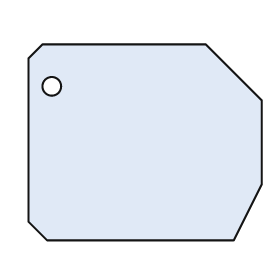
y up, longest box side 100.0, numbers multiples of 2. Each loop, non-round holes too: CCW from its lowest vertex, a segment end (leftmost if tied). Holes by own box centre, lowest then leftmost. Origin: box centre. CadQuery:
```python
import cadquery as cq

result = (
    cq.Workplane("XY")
    .moveTo(-42.0, -42.0)
    .lineTo(38.0, -42.0)
    .lineTo(50.0, -18.0)
    .lineTo(50.0, 18.0)
    .lineTo(26.0, 42.0)
    .lineTo(-44.0, 42.0)
    .lineTo(-50.0, 36.0)
    .lineTo(-50.0, -34.0)
    .close()
    .moveTo(-40.0, 24.0)
    .circle(4.0)
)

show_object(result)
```